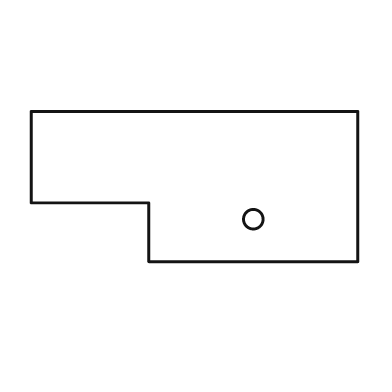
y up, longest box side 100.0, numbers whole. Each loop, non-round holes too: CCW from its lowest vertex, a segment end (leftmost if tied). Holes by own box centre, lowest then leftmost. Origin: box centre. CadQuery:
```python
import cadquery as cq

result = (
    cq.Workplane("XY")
    .moveTo(-14.0, -23.0)
    .lineTo(50.0, -23.0)
    .lineTo(50.0, 23.0)
    .lineTo(-50.0, 23.0)
    .lineTo(-50.0, -5.0)
    .lineTo(-14.0, -5.0)
    .close()
    .moveTo(18.0, -10.0)
    .circle(3.0)
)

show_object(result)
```